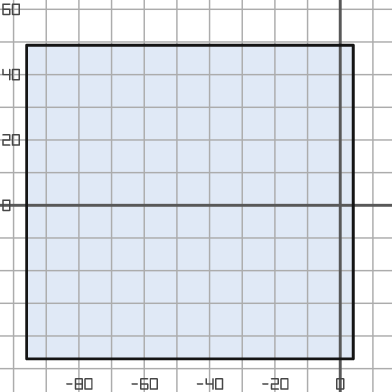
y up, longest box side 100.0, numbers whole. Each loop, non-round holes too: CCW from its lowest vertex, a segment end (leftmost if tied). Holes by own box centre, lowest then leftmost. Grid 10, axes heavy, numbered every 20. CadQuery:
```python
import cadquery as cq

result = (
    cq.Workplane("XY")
    .moveTo(-96.0, -47.0)
    .lineTo(4.0, -47.0)
    .lineTo(4.0, 49.0)
    .lineTo(-96.0, 49.0)
    .close()
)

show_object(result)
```